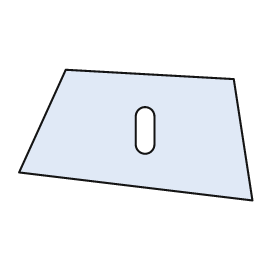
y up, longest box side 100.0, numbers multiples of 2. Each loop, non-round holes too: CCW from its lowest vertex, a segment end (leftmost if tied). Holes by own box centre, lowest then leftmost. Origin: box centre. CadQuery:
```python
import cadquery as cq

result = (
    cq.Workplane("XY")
    .moveTo(50.0, -28.0)
    .lineTo(42.0, 24.0)
    .lineTo(-30.0, 28.0)
    .lineTo(-50.0, -16.0)
    .close()
    .moveTo(0.0, -4.0)
    .threePointArc((4.0, -8.0), (8.0, -4.0))
    .lineTo(8.0, 8.0)
    .threePointArc((4.0, 12.0), (0.0, 8.0))
    .close()
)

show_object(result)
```